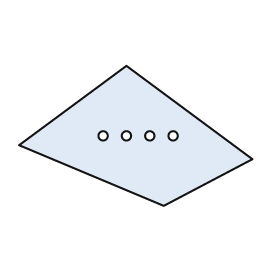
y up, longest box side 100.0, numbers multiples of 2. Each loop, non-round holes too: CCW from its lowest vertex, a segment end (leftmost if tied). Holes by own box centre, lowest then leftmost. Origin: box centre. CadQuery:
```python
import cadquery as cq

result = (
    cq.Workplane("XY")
    .moveTo(12.0, -30.0)
    .lineTo(50.0, -10.0)
    .lineTo(-4.0, 30.0)
    .lineTo(-50.0, -4.0)
    .close()
    .moveTo(-14.0, 0.0)
    .circle(2.0)
    .moveTo(-4.0, 0.0)
    .circle(2.0)
    .moveTo(6.0, 0.0)
    .circle(2.0)
    .moveTo(16.0, 0.0)
    .circle(2.0)
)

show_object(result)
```